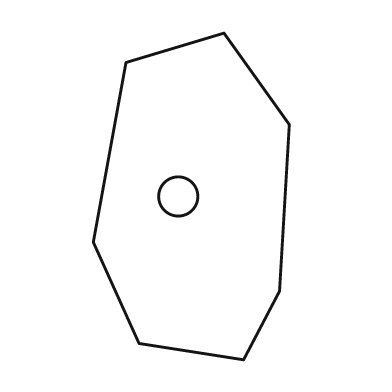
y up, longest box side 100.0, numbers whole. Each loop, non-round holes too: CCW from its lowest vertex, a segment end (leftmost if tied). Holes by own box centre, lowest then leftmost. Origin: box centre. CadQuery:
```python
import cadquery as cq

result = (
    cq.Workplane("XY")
    .moveTo(16.0, -50.0)
    .lineTo(27.0, -29.0)
    .lineTo(30.0, 22.0)
    .lineTo(10.0, 50.0)
    .lineTo(-20.0, 41.0)
    .lineTo(-30.0, -14.0)
    .lineTo(-16.0, -45.0)
    .close()
    .moveTo(-4.0, 0.0)
    .circle(6.0)
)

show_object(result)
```